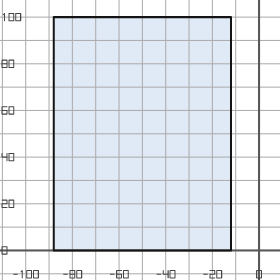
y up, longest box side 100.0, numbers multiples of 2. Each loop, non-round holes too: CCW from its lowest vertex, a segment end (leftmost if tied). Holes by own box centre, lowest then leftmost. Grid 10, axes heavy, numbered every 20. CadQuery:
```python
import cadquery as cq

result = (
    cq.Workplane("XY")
    .moveTo(-88.0, 0.0)
    .lineTo(-12.0, 0.0)
    .lineTo(-12.0, 100.0)
    .lineTo(-88.0, 100.0)
    .close()
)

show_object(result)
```